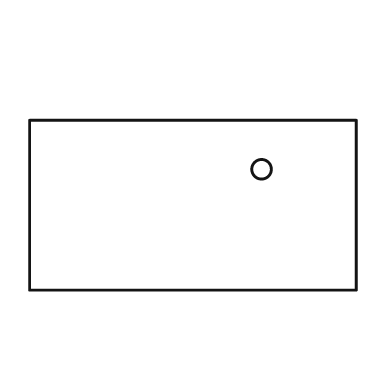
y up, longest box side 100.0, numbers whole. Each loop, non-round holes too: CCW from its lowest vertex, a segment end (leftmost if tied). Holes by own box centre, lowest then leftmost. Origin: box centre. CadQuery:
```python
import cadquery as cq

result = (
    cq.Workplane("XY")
    .moveTo(-50.0, -26.0)
    .lineTo(50.0, -26.0)
    .lineTo(50.0, 26.0)
    .lineTo(-50.0, 26.0)
    .close()
    .moveTo(21.0, 11.0)
    .circle(3.0)
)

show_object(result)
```